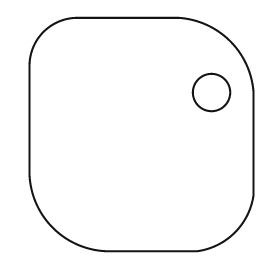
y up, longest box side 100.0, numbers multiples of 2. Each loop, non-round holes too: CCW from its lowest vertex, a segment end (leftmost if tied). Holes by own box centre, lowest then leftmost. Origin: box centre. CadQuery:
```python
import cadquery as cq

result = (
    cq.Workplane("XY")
    .moveTo(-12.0, -50.0)
    .lineTo(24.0, -50.0)
    .threePointArc((40.0, -42.0), (48.0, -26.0))
    .lineTo(48.0, 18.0)
    .threePointArc((38.0, 40.0), (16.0, 50.0))
    .lineTo(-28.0, 50.0)
    .threePointArc((-42.0, 44.0), (-48.0, 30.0))
    .lineTo(-48.0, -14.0)
    .threePointArc((-38.0, -40.0), (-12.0, -50.0))
    .close()
    .moveTo(30.0, 18.0)
    .circle(8.0)
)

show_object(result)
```